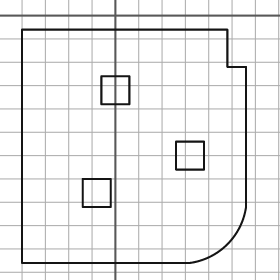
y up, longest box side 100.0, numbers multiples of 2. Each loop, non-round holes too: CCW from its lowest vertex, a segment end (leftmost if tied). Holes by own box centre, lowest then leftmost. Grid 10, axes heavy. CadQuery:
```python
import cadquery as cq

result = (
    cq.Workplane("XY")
    .moveTo(-40.0, -106.0)
    .lineTo(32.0, -106.0)
    .threePointArc((48.0, -98.0), (56.0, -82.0))
    .lineTo(56.0, -22.0)
    .lineTo(48.0, -22.0)
    .lineTo(48.0, -6.0)
    .lineTo(-40.0, -6.0)
    .close()
    .moveTo(-14.0, -82.0)
    .lineTo(-2.0, -82.0)
    .lineTo(-2.0, -70.0)
    .lineTo(-14.0, -70.0)
    .close()
    .moveTo(26.0, -66.0)
    .lineTo(38.0, -66.0)
    .lineTo(38.0, -54.0)
    .lineTo(26.0, -54.0)
    .close()
    .moveTo(-6.0, -38.0)
    .lineTo(6.0, -38.0)
    .lineTo(6.0, -26.0)
    .lineTo(-6.0, -26.0)
    .close()
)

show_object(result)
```